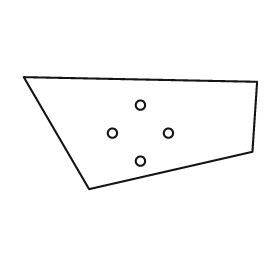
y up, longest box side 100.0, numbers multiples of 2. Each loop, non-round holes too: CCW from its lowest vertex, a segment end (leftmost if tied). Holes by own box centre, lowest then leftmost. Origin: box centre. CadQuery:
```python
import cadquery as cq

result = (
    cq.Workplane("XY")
    .moveTo(-22.0, -24.0)
    .lineTo(48.0, -8.0)
    .lineTo(50.0, 22.0)
    .lineTo(-50.0, 24.0)
    .close()
    .moveTo(0.0, -12.0)
    .circle(2.0)
    .moveTo(-12.0, 0.0)
    .circle(2.0)
    .moveTo(12.0, 0.0)
    .circle(2.0)
    .moveTo(0.0, 12.0)
    .circle(2.0)
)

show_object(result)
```